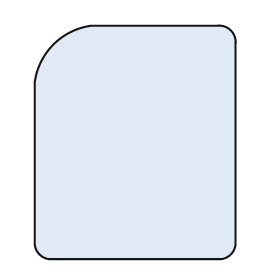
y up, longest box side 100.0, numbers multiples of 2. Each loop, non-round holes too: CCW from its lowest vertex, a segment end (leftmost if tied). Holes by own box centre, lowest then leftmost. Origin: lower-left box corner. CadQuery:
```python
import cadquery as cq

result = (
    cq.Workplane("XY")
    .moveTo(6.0, 0.0)
    .lineTo(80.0, 0.0)
    .threePointArc((84.0, 2.0), (86.0, 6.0))
    .lineTo(86.0, 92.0)
    .threePointArc((84.0, 98.0), (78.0, 100.0))
    .lineTo(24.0, 100.0)
    .threePointArc((8.0, 92.0), (0.0, 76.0))
    .lineTo(0.0, 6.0)
    .threePointArc((2.0, 2.0), (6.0, 0.0))
    .close()
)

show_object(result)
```